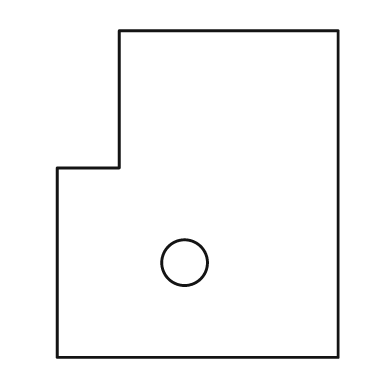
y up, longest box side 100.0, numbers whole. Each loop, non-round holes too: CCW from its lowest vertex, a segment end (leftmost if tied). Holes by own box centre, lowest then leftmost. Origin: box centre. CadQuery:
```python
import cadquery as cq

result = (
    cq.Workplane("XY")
    .moveTo(-43.0, -50.0)
    .lineTo(43.0, -50.0)
    .lineTo(43.0, 50.0)
    .lineTo(-24.0, 50.0)
    .lineTo(-24.0, 8.0)
    .lineTo(-43.0, 8.0)
    .close()
    .moveTo(-4.0, -21.0)
    .circle(7.0)
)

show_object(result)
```